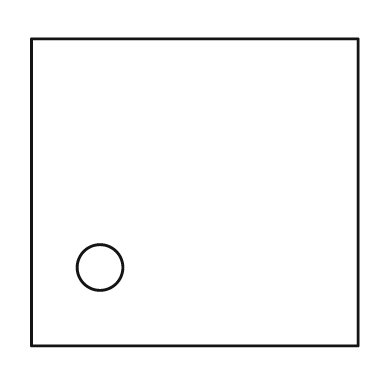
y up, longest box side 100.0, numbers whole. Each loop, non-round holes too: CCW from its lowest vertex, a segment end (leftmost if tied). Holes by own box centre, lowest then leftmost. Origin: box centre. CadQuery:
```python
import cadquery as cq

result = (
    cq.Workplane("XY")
    .moveTo(-50.0, -47.0)
    .lineTo(50.0, -47.0)
    .lineTo(50.0, 47.0)
    .lineTo(-50.0, 47.0)
    .close()
    .moveTo(-29.0, -23.0)
    .circle(7.0)
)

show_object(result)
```